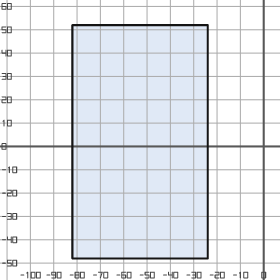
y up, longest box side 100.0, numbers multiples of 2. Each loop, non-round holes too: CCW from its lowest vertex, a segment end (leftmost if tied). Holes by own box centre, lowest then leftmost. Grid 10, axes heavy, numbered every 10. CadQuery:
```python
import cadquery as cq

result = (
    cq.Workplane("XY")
    .moveTo(-82.0, -48.0)
    .lineTo(-24.0, -48.0)
    .lineTo(-24.0, 52.0)
    .lineTo(-82.0, 52.0)
    .close()
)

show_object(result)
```